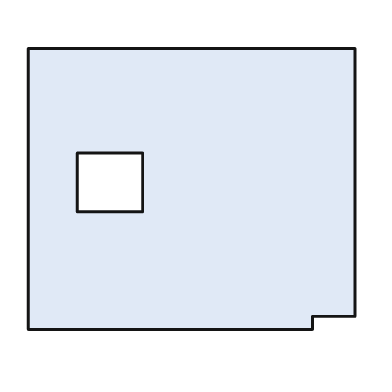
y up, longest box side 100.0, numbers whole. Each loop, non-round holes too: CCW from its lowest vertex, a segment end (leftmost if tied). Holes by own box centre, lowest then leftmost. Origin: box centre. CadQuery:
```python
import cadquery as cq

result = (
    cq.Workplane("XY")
    .moveTo(-50.0, -43.0)
    .lineTo(37.0, -43.0)
    .lineTo(37.0, -39.0)
    .lineTo(50.0, -39.0)
    .lineTo(50.0, 43.0)
    .lineTo(-50.0, 43.0)
    .close()
    .moveTo(-35.0, -7.0)
    .lineTo(-15.0, -7.0)
    .lineTo(-15.0, 11.0)
    .lineTo(-35.0, 11.0)
    .close()
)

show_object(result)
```